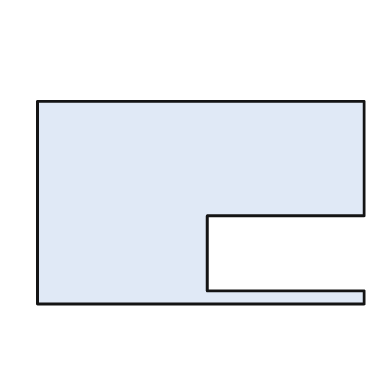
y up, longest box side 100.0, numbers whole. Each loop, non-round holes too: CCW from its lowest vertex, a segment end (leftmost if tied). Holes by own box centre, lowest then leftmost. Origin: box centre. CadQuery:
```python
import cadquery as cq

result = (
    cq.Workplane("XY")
    .moveTo(-50.0, -31.0)
    .lineTo(50.0, -31.0)
    .lineTo(50.0, -27.0)
    .lineTo(2.0, -27.0)
    .lineTo(2.0, -4.0)
    .lineTo(50.0, -4.0)
    .lineTo(50.0, 31.0)
    .lineTo(-50.0, 31.0)
    .close()
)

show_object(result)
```